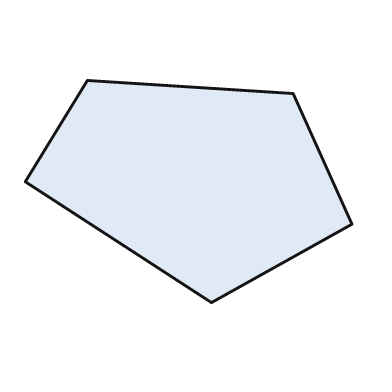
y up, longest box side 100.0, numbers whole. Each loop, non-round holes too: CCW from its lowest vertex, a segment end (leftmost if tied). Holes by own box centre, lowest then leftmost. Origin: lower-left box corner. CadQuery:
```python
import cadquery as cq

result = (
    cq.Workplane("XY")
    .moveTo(57.0, 0.0)
    .lineTo(100.0, 24.0)
    .lineTo(82.0, 64.0)
    .lineTo(19.0, 68.0)
    .lineTo(0.0, 37.0)
    .close()
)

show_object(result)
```